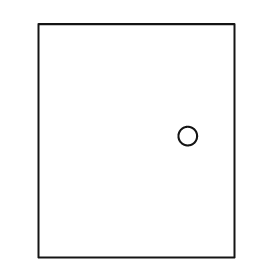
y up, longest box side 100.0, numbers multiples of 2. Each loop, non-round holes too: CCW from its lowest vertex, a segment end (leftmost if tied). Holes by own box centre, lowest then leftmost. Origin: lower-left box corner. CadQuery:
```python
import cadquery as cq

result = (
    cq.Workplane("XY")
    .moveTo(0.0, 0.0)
    .lineTo(84.0, 0.0)
    .lineTo(84.0, 100.0)
    .lineTo(0.0, 100.0)
    .close()
    .moveTo(64.0, 52.0)
    .circle(4.0)
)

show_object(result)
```